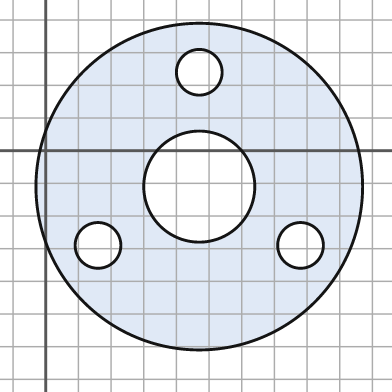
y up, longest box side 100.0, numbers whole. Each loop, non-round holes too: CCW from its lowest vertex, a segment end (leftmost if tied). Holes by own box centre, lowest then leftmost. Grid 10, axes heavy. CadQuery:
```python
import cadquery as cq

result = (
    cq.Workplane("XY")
    .moveTo(47.0, -11.0)
    .circle(50.0)
    .moveTo(16.0, -29.0)
    .circle(7.0)
    .moveTo(78.0, -29.0)
    .circle(7.0)
    .moveTo(47.0, -11.0)
    .circle(17.0)
    .moveTo(47.0, 24.0)
    .circle(7.0)
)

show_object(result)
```